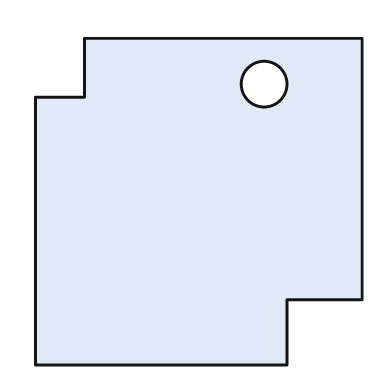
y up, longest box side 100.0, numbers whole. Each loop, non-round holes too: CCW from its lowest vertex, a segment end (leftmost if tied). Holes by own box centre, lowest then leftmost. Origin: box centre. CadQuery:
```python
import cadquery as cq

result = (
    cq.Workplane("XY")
    .moveTo(-50.0, -50.0)
    .lineTo(27.0, -50.0)
    .lineTo(27.0, -30.0)
    .lineTo(50.0, -30.0)
    .lineTo(50.0, 50.0)
    .lineTo(-35.0, 50.0)
    .lineTo(-35.0, 32.0)
    .lineTo(-50.0, 32.0)
    .close()
    .moveTo(20.0, 36.0)
    .circle(7.0)
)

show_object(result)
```